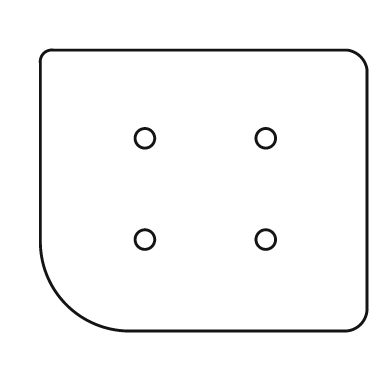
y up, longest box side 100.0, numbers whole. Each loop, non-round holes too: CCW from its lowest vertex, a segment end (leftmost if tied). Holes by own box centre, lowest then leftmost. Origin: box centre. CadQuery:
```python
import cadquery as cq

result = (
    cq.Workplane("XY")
    .moveTo(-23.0, -43.0)
    .lineTo(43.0, -43.0)
    .threePointArc((48.0, -41.0), (50.0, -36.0))
    .lineTo(50.0, 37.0)
    .threePointArc((48.0, 41.0), (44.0, 43.0))
    .lineTo(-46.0, 43.0)
    .threePointArc((-49.0, 42.0), (-50.0, 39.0))
    .lineTo(-50.0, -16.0)
    .threePointArc((-42.0, -35.0), (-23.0, -43.0))
    .close()
    .moveTo(-18.0, -15.0)
    .circle(3.0)
    .moveTo(19.0, -15.0)
    .circle(3.0)
    .moveTo(-18.0, 16.0)
    .circle(3.0)
    .moveTo(19.0, 16.0)
    .circle(3.0)
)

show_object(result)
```